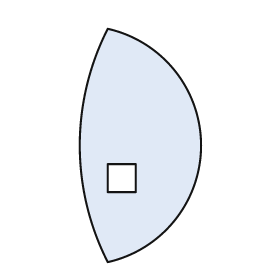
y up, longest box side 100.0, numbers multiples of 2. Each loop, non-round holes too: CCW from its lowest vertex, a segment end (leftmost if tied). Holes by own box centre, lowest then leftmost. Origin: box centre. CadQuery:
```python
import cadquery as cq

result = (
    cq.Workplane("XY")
    .moveTo(-14.0, -50.0)
    .threePointArc((26.0, 0.0), (-14.0, 50.0))
    .threePointArc((-26.0, 0.0), (-14.0, -50.0))
    .close()
    .moveTo(-14.0, -20.0)
    .lineTo(-2.0, -20.0)
    .lineTo(-2.0, -8.0)
    .lineTo(-14.0, -8.0)
    .close()
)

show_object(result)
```